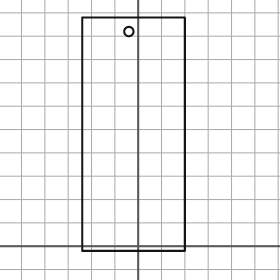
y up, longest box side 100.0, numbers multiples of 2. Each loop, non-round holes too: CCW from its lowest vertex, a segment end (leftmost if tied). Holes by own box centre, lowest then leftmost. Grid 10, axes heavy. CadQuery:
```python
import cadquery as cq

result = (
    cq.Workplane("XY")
    .moveTo(-24.0, -2.0)
    .lineTo(20.0, -2.0)
    .lineTo(20.0, 98.0)
    .lineTo(-24.0, 98.0)
    .close()
    .moveTo(-4.0, 92.0)
    .circle(2.0)
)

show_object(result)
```